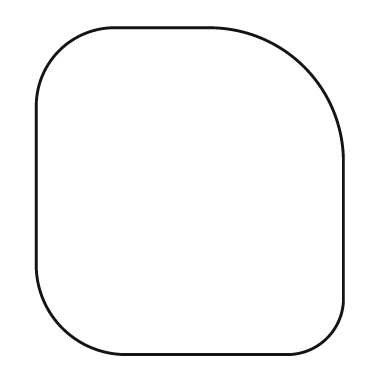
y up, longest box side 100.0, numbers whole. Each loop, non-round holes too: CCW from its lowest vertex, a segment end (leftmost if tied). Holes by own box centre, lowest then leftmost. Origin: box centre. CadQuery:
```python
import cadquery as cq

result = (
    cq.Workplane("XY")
    .moveTo(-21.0, -50.0)
    .lineTo(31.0, -50.0)
    .threePointArc((42.0, -45.0), (47.0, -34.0))
    .lineTo(47.0, 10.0)
    .threePointArc((35.0, 38.0), (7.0, 50.0))
    .lineTo(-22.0, 50.0)
    .threePointArc((-40.0, 43.0), (-47.0, 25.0))
    .lineTo(-47.0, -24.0)
    .threePointArc((-39.0, -42.0), (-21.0, -50.0))
    .close()
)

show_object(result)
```